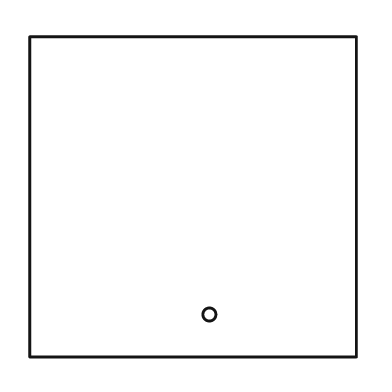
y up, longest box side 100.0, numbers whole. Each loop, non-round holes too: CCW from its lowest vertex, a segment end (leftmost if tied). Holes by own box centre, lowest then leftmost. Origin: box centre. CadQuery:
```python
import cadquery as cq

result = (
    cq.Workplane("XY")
    .moveTo(-50.0, -49.0)
    .lineTo(50.0, -49.0)
    .lineTo(50.0, 49.0)
    .lineTo(-50.0, 49.0)
    .close()
    .moveTo(5.0, -36.0)
    .circle(2.0)
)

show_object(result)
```